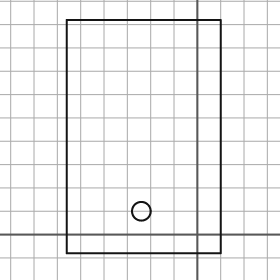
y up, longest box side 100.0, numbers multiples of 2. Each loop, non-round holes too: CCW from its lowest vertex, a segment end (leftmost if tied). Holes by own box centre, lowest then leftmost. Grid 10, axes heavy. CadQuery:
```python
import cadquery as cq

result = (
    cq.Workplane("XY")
    .moveTo(-56.0, -8.0)
    .lineTo(10.0, -8.0)
    .lineTo(10.0, 92.0)
    .lineTo(-56.0, 92.0)
    .close()
    .moveTo(-24.0, 10.0)
    .circle(4.0)
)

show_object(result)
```